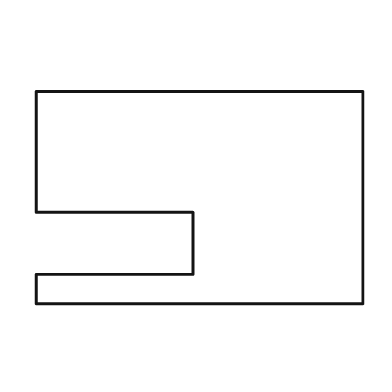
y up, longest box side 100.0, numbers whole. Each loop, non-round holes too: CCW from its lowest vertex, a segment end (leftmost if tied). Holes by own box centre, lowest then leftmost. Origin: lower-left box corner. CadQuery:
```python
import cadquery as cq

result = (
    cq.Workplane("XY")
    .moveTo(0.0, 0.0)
    .lineTo(100.0, 0.0)
    .lineTo(100.0, 65.0)
    .lineTo(0.0, 65.0)
    .lineTo(0.0, 28.0)
    .lineTo(48.0, 28.0)
    .lineTo(48.0, 9.0)
    .lineTo(0.0, 9.0)
    .close()
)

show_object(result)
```